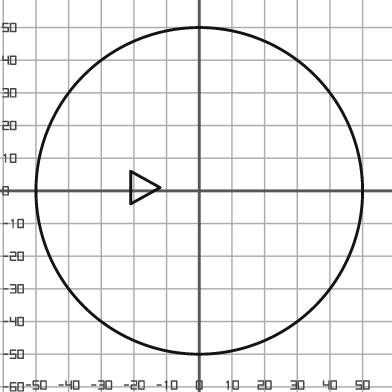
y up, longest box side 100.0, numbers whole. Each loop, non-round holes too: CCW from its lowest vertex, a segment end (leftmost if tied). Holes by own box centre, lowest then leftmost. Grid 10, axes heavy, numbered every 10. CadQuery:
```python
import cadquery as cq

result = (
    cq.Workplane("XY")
    .moveTo(0.0, 0.0)
    .circle(50.0)
    .moveTo(-21.0, -4.0)
    .lineTo(-12.0, 1.0)
    .lineTo(-21.0, 6.0)
    .close()
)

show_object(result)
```